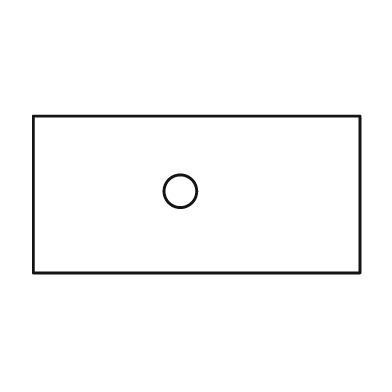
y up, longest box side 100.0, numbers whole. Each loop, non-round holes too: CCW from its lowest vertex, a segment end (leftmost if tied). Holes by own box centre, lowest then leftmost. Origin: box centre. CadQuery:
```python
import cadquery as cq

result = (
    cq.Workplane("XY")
    .moveTo(-50.0, -24.0)
    .lineTo(50.0, -24.0)
    .lineTo(50.0, 24.0)
    .lineTo(-50.0, 24.0)
    .close()
    .moveTo(-5.0, 1.0)
    .circle(5.0)
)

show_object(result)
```